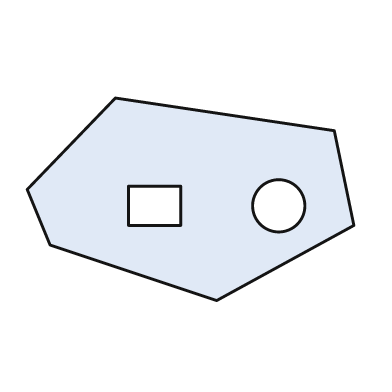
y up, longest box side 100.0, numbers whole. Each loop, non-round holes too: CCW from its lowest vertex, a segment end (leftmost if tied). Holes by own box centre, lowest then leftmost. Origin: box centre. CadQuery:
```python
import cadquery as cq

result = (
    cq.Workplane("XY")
    .moveTo(8.0, -31.0)
    .lineTo(50.0, -8.0)
    .lineTo(44.0, 21.0)
    .lineTo(-23.0, 31.0)
    .lineTo(-50.0, 3.0)
    .lineTo(-43.0, -14.0)
    .close()
    .moveTo(-19.0, -8.0)
    .lineTo(-3.0, -8.0)
    .lineTo(-3.0, 4.0)
    .lineTo(-19.0, 4.0)
    .close()
    .moveTo(27.0, -2.0)
    .circle(8.0)
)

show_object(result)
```